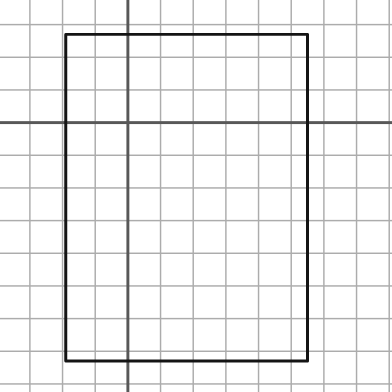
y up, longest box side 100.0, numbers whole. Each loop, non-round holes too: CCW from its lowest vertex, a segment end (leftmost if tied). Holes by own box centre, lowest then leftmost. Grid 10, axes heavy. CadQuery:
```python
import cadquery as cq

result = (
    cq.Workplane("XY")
    .moveTo(-19.0, -73.0)
    .lineTo(55.0, -73.0)
    .lineTo(55.0, 27.0)
    .lineTo(-19.0, 27.0)
    .close()
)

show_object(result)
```